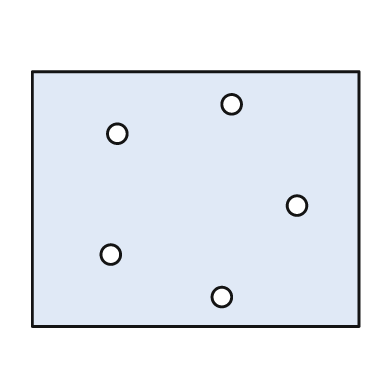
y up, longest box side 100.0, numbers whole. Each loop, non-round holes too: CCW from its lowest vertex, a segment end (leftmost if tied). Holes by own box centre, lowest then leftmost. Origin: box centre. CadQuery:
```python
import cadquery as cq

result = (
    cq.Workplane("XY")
    .moveTo(-50.0, -39.0)
    .lineTo(50.0, -39.0)
    .lineTo(50.0, 39.0)
    .lineTo(-50.0, 39.0)
    .close()
    .moveTo(8.0, -30.0)
    .circle(3.0)
    .moveTo(-26.0, -17.0)
    .circle(3.0)
    .moveTo(31.0, -2.0)
    .circle(3.0)
    .moveTo(-24.0, 20.0)
    .circle(3.0)
    .moveTo(11.0, 29.0)
    .circle(3.0)
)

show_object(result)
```